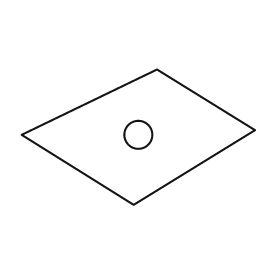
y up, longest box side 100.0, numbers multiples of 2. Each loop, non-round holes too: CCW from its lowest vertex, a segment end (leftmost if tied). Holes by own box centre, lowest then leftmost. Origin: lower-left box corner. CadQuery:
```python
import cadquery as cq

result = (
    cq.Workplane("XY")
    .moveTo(48.0, 0.0)
    .lineTo(100.0, 32.0)
    .lineTo(58.0, 58.0)
    .lineTo(0.0, 30.0)
    .close()
    .moveTo(50.0, 30.0)
    .circle(6.0)
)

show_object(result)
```